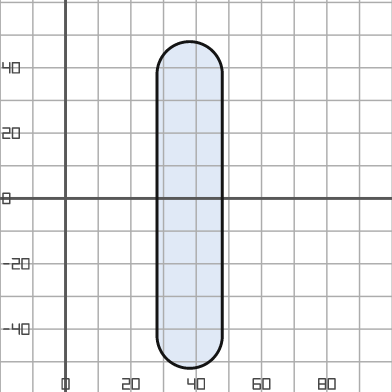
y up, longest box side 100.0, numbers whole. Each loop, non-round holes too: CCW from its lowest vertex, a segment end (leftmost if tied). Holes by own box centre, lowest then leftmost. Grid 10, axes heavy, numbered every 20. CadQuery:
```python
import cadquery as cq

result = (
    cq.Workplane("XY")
    .moveTo(28.0, -42.0)
    .threePointArc((38.0, -52.0), (48.0, -42.0))
    .lineTo(48.0, 38.0)
    .threePointArc((38.0, 48.0), (28.0, 38.0))
    .close()
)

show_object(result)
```